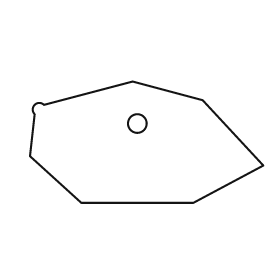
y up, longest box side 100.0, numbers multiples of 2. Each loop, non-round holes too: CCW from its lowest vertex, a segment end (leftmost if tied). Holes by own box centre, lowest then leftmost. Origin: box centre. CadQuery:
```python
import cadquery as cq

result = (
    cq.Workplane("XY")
    .moveTo(-28.0, -26.0)
    .lineTo(20.0, -26.0)
    .lineTo(50.0, -10.0)
    .lineTo(24.0, 18.0)
    .lineTo(-6.0, 26.0)
    .lineTo(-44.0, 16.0)
    .threePointArc((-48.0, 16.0), (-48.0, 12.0))
    .lineTo(-50.0, -6.0)
    .close()
    .moveTo(-4.0, 8.0)
    .circle(4.0)
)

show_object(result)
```